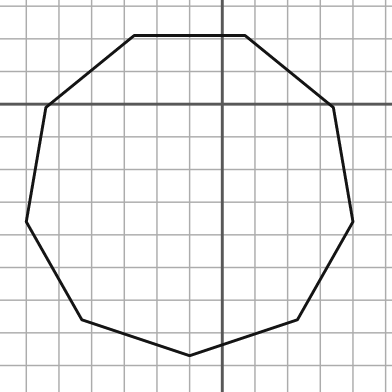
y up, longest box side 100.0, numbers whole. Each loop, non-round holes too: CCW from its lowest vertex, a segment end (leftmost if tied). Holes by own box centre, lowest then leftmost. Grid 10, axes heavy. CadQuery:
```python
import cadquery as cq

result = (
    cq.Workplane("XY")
    .moveTo(-10.0, -77.0)
    .lineTo(23.0, -66.0)
    .lineTo(40.0, -36.0)
    .lineTo(34.0, -1.0)
    .lineTo(7.0, 21.0)
    .lineTo(-27.0, 21.0)
    .lineTo(-54.0, -1.0)
    .lineTo(-60.0, -36.0)
    .lineTo(-43.0, -66.0)
    .close()
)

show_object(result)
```